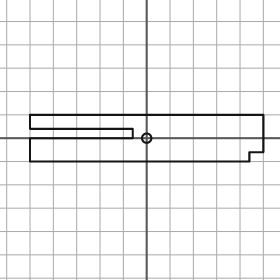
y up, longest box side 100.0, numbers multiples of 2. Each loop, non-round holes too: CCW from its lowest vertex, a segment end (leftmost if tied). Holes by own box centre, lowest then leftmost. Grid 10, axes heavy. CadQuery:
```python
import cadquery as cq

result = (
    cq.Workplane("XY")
    .moveTo(-50.0, -10.0)
    .lineTo(44.0, -10.0)
    .lineTo(44.0, -6.0)
    .lineTo(50.0, -6.0)
    .lineTo(50.0, 10.0)
    .lineTo(-50.0, 10.0)
    .lineTo(-50.0, 4.0)
    .lineTo(-6.0, 4.0)
    .lineTo(-6.0, 0.0)
    .lineTo(-50.0, 0.0)
    .close()
    .moveTo(0.0, 0.0)
    .circle(2.0)
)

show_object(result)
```